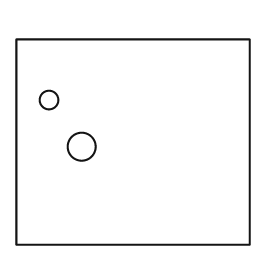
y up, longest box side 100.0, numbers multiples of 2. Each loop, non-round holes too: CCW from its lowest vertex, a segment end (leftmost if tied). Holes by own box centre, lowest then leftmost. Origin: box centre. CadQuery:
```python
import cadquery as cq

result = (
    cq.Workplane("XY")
    .moveTo(-50.0, -44.0)
    .lineTo(50.0, -44.0)
    .lineTo(50.0, 44.0)
    .lineTo(-50.0, 44.0)
    .close()
    .moveTo(-22.0, -2.0)
    .circle(6.0)
    .moveTo(-36.0, 18.0)
    .circle(4.0)
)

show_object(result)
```